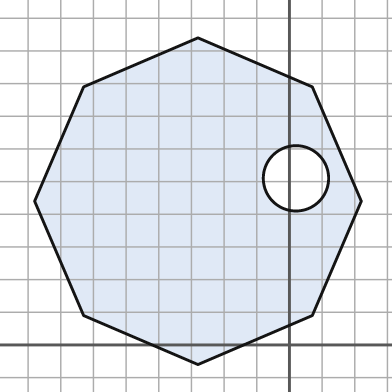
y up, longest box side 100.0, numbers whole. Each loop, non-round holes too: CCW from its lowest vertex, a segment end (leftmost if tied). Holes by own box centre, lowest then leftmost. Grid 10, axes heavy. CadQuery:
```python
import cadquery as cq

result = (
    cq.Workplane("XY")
    .moveTo(-28.0, -6.0)
    .lineTo(7.0, 9.0)
    .lineTo(22.0, 44.0)
    .lineTo(7.0, 79.0)
    .lineTo(-28.0, 94.0)
    .lineTo(-63.0, 79.0)
    .lineTo(-78.0, 44.0)
    .lineTo(-63.0, 9.0)
    .close()
    .moveTo(2.0, 51.0)
    .circle(10.0)
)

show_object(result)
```